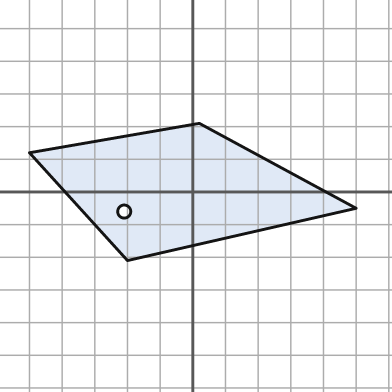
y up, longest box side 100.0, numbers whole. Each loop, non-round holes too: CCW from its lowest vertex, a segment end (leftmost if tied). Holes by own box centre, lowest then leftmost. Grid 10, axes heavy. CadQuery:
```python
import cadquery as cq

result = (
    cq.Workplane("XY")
    .moveTo(-20.0, -21.0)
    .lineTo(50.0, -5.0)
    .lineTo(2.0, 21.0)
    .lineTo(-50.0, 12.0)
    .close()
    .moveTo(-21.0, -6.0)
    .circle(2.0)
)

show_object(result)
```